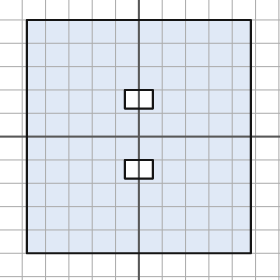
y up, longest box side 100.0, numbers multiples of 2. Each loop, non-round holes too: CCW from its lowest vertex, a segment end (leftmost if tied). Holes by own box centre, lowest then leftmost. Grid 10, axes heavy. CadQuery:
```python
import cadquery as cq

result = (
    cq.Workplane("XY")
    .moveTo(-48.0, -50.0)
    .lineTo(48.0, -50.0)
    .lineTo(48.0, 50.0)
    .lineTo(-48.0, 50.0)
    .close()
    .moveTo(-6.0, -18.0)
    .lineTo(6.0, -18.0)
    .lineTo(6.0, -10.0)
    .lineTo(-6.0, -10.0)
    .close()
    .moveTo(-6.0, 12.0)
    .lineTo(6.0, 12.0)
    .lineTo(6.0, 20.0)
    .lineTo(-6.0, 20.0)
    .close()
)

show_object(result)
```